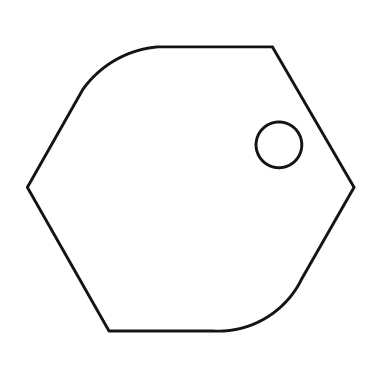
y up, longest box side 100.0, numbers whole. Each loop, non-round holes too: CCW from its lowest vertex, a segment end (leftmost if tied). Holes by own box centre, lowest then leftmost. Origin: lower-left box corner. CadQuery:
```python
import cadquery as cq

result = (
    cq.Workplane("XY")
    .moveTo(25.0, 0.0)
    .lineTo(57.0, 0.0)
    .threePointArc((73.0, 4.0), (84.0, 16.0))
    .lineTo(100.0, 44.0)
    .lineTo(75.0, 87.0)
    .lineTo(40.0, 87.0)
    .threePointArc((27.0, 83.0), (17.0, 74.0))
    .lineTo(0.0, 44.0)
    .close()
    .moveTo(77.0, 57.0)
    .circle(7.0)
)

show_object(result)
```